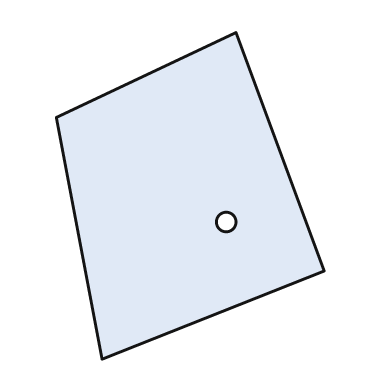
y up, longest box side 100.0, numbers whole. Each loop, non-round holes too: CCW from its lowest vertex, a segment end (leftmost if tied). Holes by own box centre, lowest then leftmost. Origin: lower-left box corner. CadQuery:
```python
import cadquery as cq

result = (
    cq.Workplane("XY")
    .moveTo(14.0, 0.0)
    .lineTo(82.0, 27.0)
    .lineTo(55.0, 100.0)
    .lineTo(0.0, 74.0)
    .close()
    .moveTo(52.0, 42.0)
    .circle(3.0)
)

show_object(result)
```